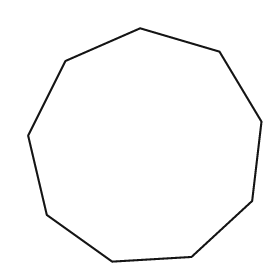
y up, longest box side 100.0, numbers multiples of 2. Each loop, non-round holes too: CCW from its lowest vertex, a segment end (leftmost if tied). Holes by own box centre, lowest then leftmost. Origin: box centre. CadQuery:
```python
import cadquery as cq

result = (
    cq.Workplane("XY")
    .moveTo(-14.0, -50.0)
    .lineTo(20.0, -48.0)
    .lineTo(46.0, -24.0)
    .lineTo(50.0, 10.0)
    .lineTo(32.0, 40.0)
    .lineTo(-2.0, 50.0)
    .lineTo(-34.0, 36.0)
    .lineTo(-50.0, 4.0)
    .lineTo(-42.0, -30.0)
    .close()
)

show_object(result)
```